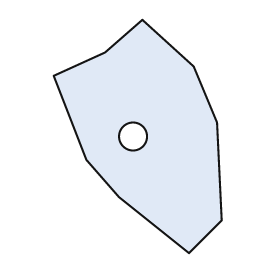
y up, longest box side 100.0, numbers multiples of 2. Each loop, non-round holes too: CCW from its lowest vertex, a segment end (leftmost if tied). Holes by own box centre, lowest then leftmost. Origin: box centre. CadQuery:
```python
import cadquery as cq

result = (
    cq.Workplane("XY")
    .moveTo(22.0, -50.0)
    .lineTo(36.0, -36.0)
    .lineTo(34.0, 6.0)
    .lineTo(24.0, 30.0)
    .lineTo(2.0, 50.0)
    .lineTo(-14.0, 36.0)
    .lineTo(-36.0, 26.0)
    .lineTo(-22.0, -10.0)
    .lineTo(-8.0, -26.0)
    .close()
    .moveTo(-2.0, 0.0)
    .circle(6.0)
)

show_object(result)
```